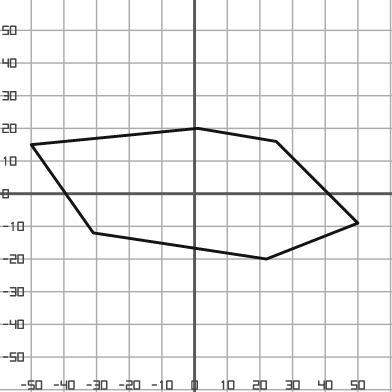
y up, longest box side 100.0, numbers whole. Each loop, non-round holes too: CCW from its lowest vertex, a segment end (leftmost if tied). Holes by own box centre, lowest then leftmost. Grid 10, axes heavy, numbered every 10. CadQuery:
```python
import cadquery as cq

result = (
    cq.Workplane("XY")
    .moveTo(22.0, -20.0)
    .lineTo(50.0, -9.0)
    .lineTo(25.0, 16.0)
    .lineTo(1.0, 20.0)
    .lineTo(-50.0, 15.0)
    .lineTo(-31.0, -12.0)
    .close()
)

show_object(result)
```